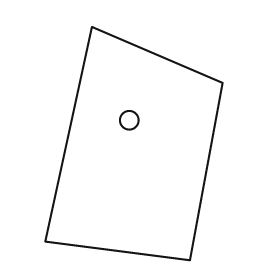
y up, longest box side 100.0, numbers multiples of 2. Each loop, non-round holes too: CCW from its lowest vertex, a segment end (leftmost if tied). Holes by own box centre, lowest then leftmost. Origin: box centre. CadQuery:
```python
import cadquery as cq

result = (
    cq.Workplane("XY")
    .moveTo(24.0, -50.0)
    .lineTo(38.0, 26.0)
    .lineTo(-18.0, 50.0)
    .lineTo(-38.0, -42.0)
    .close()
    .moveTo(-2.0, 10.0)
    .circle(4.0)
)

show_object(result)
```